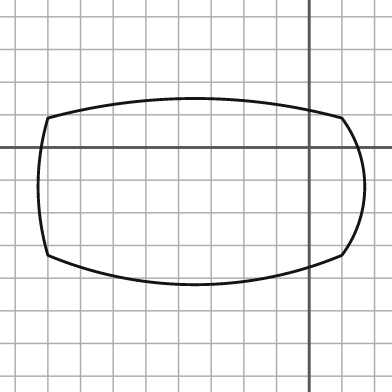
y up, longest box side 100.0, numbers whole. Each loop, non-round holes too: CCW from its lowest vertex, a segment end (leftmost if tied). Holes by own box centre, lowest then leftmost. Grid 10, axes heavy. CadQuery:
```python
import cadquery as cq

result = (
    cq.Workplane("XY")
    .moveTo(-80.0, -33.0)
    .threePointArc((-35.0, -42.0), (10.0, -33.0))
    .threePointArc((17.0, -12.0), (10.0, 9.0))
    .threePointArc((-35.0, 15.0), (-80.0, 9.0))
    .threePointArc((-83.0, -12.0), (-80.0, -33.0))
    .close()
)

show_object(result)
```